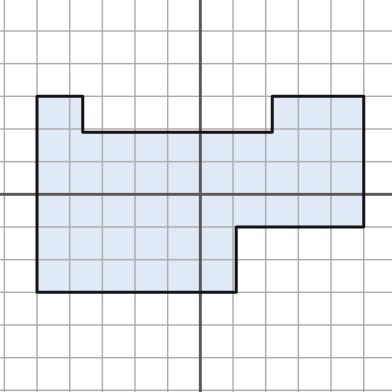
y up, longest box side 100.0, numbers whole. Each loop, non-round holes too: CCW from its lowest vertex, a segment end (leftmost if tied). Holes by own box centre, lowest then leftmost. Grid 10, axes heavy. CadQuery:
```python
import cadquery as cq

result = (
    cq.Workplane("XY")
    .moveTo(-50.0, -30.0)
    .lineTo(11.0, -30.0)
    .lineTo(11.0, -10.0)
    .lineTo(50.0, -10.0)
    .lineTo(50.0, 30.0)
    .lineTo(22.0, 30.0)
    .lineTo(22.0, 19.0)
    .lineTo(-36.0, 19.0)
    .lineTo(-36.0, 30.0)
    .lineTo(-50.0, 30.0)
    .close()
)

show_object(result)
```